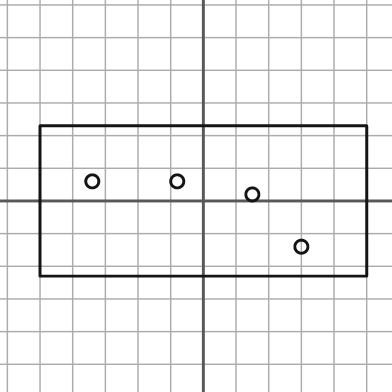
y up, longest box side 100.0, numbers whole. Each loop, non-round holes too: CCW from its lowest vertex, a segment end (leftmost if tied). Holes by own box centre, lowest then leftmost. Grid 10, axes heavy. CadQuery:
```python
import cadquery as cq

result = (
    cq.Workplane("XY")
    .moveTo(-50.0, -23.0)
    .lineTo(50.0, -23.0)
    .lineTo(50.0, 23.0)
    .lineTo(-50.0, 23.0)
    .close()
    .moveTo(30.0, -14.0)
    .circle(2.0)
    .moveTo(15.0, 2.0)
    .circle(2.0)
    .moveTo(-34.0, 6.0)
    .circle(2.0)
    .moveTo(-8.0, 6.0)
    .circle(2.0)
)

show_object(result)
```